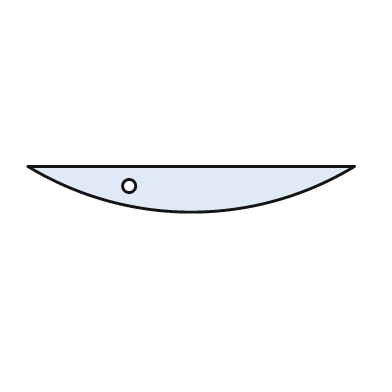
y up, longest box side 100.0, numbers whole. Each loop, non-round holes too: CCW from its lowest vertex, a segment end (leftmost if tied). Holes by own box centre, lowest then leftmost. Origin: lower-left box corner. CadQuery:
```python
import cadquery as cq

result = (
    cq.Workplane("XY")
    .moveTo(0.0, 14.0)
    .threePointArc((50.0, 0.0), (100.0, 14.0))
    .close()
    .moveTo(31.0, 8.0)
    .circle(2.0)
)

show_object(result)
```